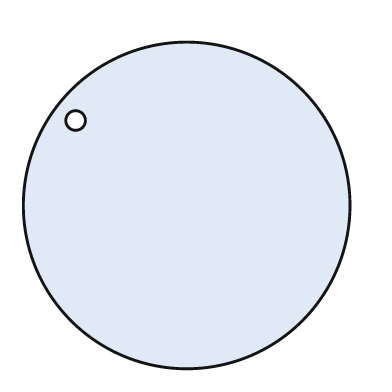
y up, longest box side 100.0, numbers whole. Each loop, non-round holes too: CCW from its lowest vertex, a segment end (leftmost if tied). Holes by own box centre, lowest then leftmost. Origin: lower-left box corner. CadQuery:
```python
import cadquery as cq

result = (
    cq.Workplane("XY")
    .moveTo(50.0, 50.0)
    .circle(50.0)
    .moveTo(16.0, 76.0)
    .circle(3.0)
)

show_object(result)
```